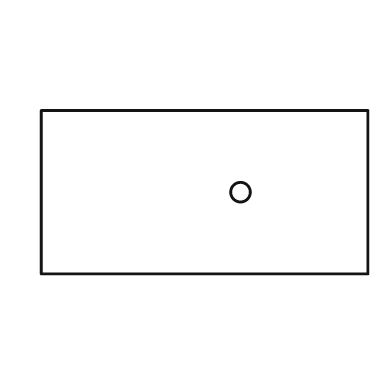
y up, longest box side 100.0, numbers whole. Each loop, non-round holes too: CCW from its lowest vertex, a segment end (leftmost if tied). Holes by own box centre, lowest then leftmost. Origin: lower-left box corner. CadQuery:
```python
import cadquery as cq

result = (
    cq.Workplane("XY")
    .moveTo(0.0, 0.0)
    .lineTo(100.0, 0.0)
    .lineTo(100.0, 50.0)
    .lineTo(0.0, 50.0)
    .close()
    .moveTo(61.0, 25.0)
    .circle(3.0)
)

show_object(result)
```